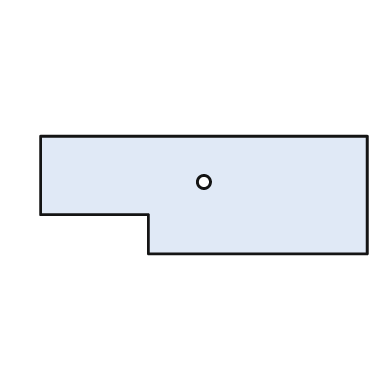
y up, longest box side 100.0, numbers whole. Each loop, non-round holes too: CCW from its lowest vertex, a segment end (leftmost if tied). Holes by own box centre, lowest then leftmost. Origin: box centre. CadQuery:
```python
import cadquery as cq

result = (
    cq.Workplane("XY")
    .moveTo(-17.0, -18.0)
    .lineTo(50.0, -18.0)
    .lineTo(50.0, 18.0)
    .lineTo(-50.0, 18.0)
    .lineTo(-50.0, -6.0)
    .lineTo(-17.0, -6.0)
    .close()
    .moveTo(0.0, 4.0)
    .circle(2.0)
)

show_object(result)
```